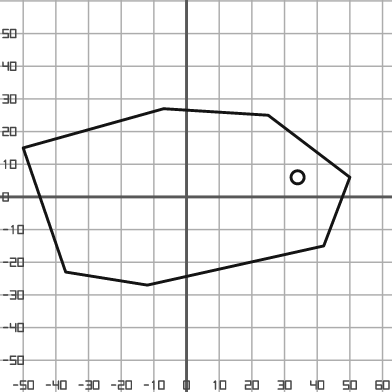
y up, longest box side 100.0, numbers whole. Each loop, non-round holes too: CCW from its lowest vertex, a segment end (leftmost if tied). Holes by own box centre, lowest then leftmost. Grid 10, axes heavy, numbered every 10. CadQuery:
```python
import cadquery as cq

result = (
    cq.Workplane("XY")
    .moveTo(-12.0, -27.0)
    .lineTo(42.0, -15.0)
    .lineTo(50.0, 6.0)
    .lineTo(25.0, 25.0)
    .lineTo(-7.0, 27.0)
    .lineTo(-50.0, 15.0)
    .lineTo(-37.0, -23.0)
    .close()
    .moveTo(34.0, 6.0)
    .circle(2.0)
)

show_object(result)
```